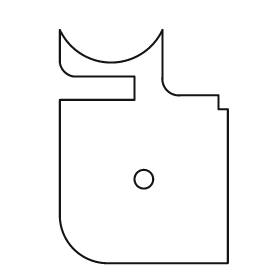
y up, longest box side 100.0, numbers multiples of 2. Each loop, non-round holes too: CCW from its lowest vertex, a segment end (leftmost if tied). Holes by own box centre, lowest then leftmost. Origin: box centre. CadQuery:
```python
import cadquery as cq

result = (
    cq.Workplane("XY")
    .moveTo(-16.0, -50.0)
    .lineTo(36.0, -50.0)
    .lineTo(36.0, 16.0)
    .lineTo(32.0, 16.0)
    .lineTo(32.0, 22.0)
    .lineTo(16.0, 22.0)
    .threePointArc((10.0, 24.0), (8.0, 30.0))
    .lineTo(8.0, 50.0)
    .threePointArc((-14.0, 36.0), (-36.0, 50.0))
    .lineTo(-36.0, 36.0)
    .threePointArc((-34.0, 32.0), (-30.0, 30.0))
    .lineTo(-4.0, 30.0)
    .lineTo(-4.0, 20.0)
    .lineTo(-36.0, 20.0)
    .lineTo(-36.0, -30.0)
    .threePointArc((-30.0, -44.0), (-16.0, -50.0))
    .close()
    .moveTo(0.0, -14.0)
    .circle(4.0)
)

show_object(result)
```